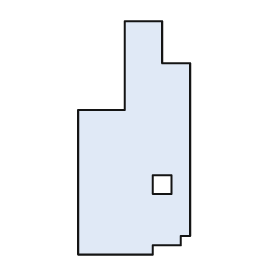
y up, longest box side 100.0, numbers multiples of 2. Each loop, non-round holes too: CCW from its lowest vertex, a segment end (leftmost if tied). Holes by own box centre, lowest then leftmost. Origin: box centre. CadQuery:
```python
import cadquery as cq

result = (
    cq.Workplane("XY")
    .moveTo(-24.0, -50.0)
    .lineTo(8.0, -50.0)
    .lineTo(8.0, -46.0)
    .lineTo(20.0, -46.0)
    .lineTo(20.0, -42.0)
    .lineTo(24.0, -42.0)
    .lineTo(24.0, 32.0)
    .lineTo(12.0, 32.0)
    .lineTo(12.0, 50.0)
    .lineTo(-4.0, 50.0)
    .lineTo(-4.0, 12.0)
    .lineTo(-24.0, 12.0)
    .close()
    .moveTo(8.0, -24.0)
    .lineTo(16.0, -24.0)
    .lineTo(16.0, -16.0)
    .lineTo(8.0, -16.0)
    .close()
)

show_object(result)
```